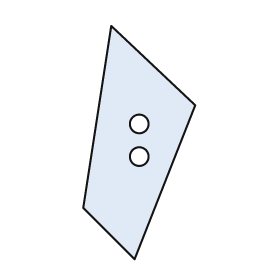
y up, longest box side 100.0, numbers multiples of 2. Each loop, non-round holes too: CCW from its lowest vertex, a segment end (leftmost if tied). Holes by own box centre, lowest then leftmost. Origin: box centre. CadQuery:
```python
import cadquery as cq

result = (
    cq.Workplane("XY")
    .moveTo(-2.0, -50.0)
    .lineTo(24.0, 16.0)
    .lineTo(-12.0, 50.0)
    .lineTo(-24.0, -28.0)
    .close()
    .moveTo(0.0, -6.0)
    .circle(4.0)
    .moveTo(0.0, 8.0)
    .circle(4.0)
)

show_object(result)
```